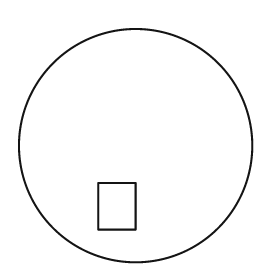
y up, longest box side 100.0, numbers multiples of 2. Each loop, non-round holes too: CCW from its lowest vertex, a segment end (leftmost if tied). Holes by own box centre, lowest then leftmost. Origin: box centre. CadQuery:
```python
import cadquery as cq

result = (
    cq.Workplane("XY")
    .moveTo(0.0, 0.0)
    .circle(50.0)
    .moveTo(-16.0, -36.0)
    .lineTo(0.0, -36.0)
    .lineTo(0.0, -16.0)
    .lineTo(-16.0, -16.0)
    .close()
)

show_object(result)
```